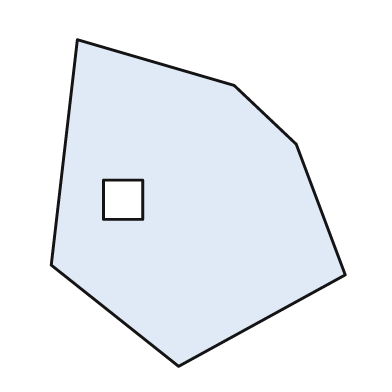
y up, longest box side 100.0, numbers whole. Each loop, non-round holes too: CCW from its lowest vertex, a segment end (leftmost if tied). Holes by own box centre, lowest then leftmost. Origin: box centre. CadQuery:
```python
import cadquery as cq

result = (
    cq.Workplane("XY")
    .moveTo(-6.0, -50.0)
    .lineTo(45.0, -22.0)
    .lineTo(30.0, 18.0)
    .lineTo(11.0, 36.0)
    .lineTo(-37.0, 50.0)
    .lineTo(-45.0, -19.0)
    .close()
    .moveTo(-29.0, -5.0)
    .lineTo(-17.0, -5.0)
    .lineTo(-17.0, 7.0)
    .lineTo(-29.0, 7.0)
    .close()
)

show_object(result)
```